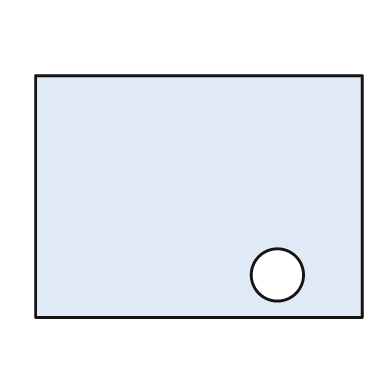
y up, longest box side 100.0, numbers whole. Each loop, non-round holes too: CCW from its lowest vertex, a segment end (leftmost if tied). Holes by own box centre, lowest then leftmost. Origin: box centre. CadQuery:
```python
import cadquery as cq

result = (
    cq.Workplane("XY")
    .moveTo(-50.0, -37.0)
    .lineTo(50.0, -37.0)
    .lineTo(50.0, 37.0)
    .lineTo(-50.0, 37.0)
    .close()
    .moveTo(24.0, -24.0)
    .circle(8.0)
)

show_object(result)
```